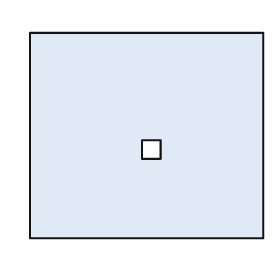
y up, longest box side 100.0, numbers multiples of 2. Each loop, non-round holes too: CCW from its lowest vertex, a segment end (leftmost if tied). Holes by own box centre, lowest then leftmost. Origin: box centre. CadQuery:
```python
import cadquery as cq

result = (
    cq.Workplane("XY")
    .moveTo(-50.0, -44.0)
    .lineTo(50.0, -44.0)
    .lineTo(50.0, 44.0)
    .lineTo(-50.0, 44.0)
    .close()
    .moveTo(-2.0, -10.0)
    .lineTo(6.0, -10.0)
    .lineTo(6.0, -2.0)
    .lineTo(-2.0, -2.0)
    .close()
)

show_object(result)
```